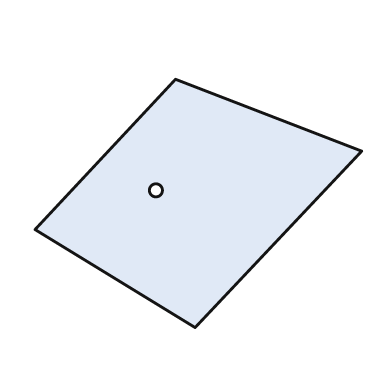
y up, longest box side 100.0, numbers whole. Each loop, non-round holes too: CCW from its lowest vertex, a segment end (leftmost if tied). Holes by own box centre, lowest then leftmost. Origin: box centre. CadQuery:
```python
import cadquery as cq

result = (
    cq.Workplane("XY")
    .moveTo(-1.0, -38.0)
    .lineTo(50.0, 16.0)
    .lineTo(-7.0, 38.0)
    .lineTo(-50.0, -8.0)
    .close()
    .moveTo(-13.0, 4.0)
    .circle(2.0)
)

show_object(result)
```